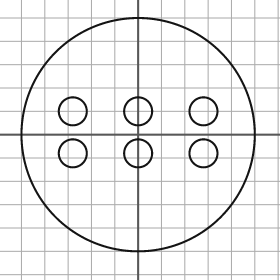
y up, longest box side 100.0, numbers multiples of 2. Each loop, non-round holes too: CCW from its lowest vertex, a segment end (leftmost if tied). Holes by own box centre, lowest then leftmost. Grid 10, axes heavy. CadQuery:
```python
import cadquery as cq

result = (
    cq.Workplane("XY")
    .moveTo(0.0, 0.0)
    .circle(50.0)
    .moveTo(-28.0, -8.0)
    .circle(6.0)
    .moveTo(0.0, -8.0)
    .circle(6.0)
    .moveTo(28.0, -8.0)
    .circle(6.0)
    .moveTo(-28.0, 10.0)
    .circle(6.0)
    .moveTo(0.0, 10.0)
    .circle(6.0)
    .moveTo(28.0, 10.0)
    .circle(6.0)
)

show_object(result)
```